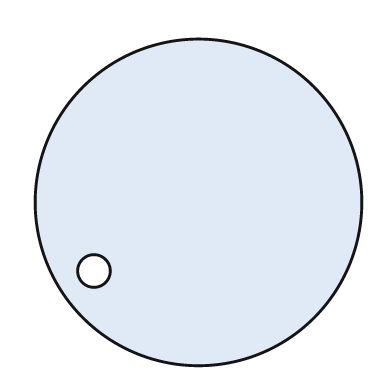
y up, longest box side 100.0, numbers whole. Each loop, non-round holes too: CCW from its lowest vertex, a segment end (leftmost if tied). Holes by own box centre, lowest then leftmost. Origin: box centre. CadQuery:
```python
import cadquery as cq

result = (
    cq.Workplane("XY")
    .moveTo(0.0, 0.0)
    .circle(50.0)
    .moveTo(-32.0, -21.0)
    .circle(5.0)
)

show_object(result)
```